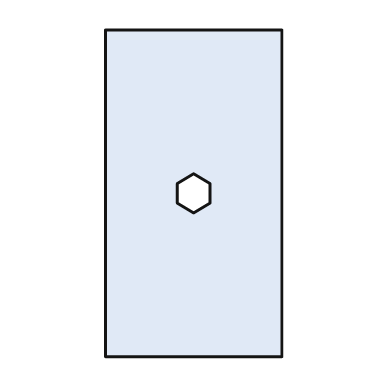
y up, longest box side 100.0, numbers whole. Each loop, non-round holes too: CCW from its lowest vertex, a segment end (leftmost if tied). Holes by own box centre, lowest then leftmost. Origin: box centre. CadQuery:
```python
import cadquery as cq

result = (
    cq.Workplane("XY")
    .moveTo(-27.0, -50.0)
    .lineTo(27.0, -50.0)
    .lineTo(27.0, 50.0)
    .lineTo(-27.0, 50.0)
    .close()
    .moveTo(0.0, -6.0)
    .lineTo(5.0, -3.0)
    .lineTo(5.0, 3.0)
    .lineTo(0.0, 6.0)
    .lineTo(-5.0, 3.0)
    .lineTo(-5.0, -3.0)
    .close()
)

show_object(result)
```